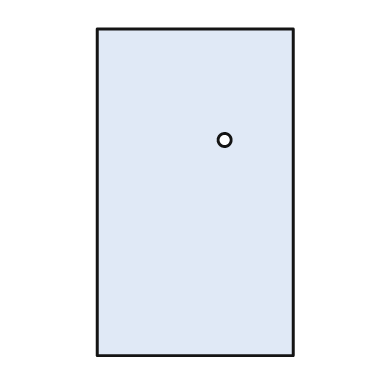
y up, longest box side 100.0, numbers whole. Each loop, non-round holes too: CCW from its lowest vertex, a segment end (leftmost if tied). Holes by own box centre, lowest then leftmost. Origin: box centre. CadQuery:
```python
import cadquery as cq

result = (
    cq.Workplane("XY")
    .moveTo(-30.0, -50.0)
    .lineTo(30.0, -50.0)
    .lineTo(30.0, 50.0)
    .lineTo(-30.0, 50.0)
    .close()
    .moveTo(9.0, 16.0)
    .circle(2.0)
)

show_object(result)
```